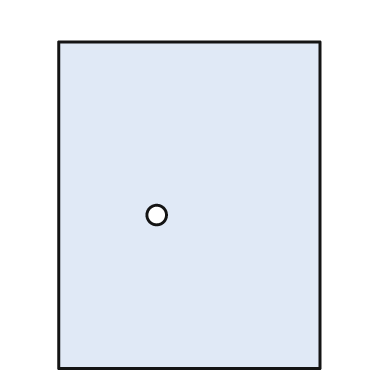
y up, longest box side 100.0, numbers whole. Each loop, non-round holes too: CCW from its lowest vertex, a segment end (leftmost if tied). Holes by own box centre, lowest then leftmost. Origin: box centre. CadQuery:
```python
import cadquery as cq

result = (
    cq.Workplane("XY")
    .moveTo(-40.0, -50.0)
    .lineTo(40.0, -50.0)
    .lineTo(40.0, 50.0)
    .lineTo(-40.0, 50.0)
    .close()
    .moveTo(-10.0, -3.0)
    .circle(3.0)
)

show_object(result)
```